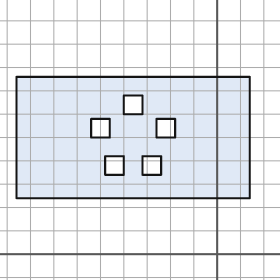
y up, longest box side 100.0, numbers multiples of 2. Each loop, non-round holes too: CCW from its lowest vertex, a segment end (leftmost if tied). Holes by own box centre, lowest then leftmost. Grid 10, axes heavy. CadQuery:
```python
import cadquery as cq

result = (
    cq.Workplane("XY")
    .moveTo(-86.0, 24.0)
    .lineTo(14.0, 24.0)
    .lineTo(14.0, 76.0)
    .lineTo(-86.0, 76.0)
    .close()
    .moveTo(-48.0, 34.0)
    .lineTo(-40.0, 34.0)
    .lineTo(-40.0, 42.0)
    .lineTo(-48.0, 42.0)
    .close()
    .moveTo(-32.0, 34.0)
    .lineTo(-24.0, 34.0)
    .lineTo(-24.0, 42.0)
    .lineTo(-32.0, 42.0)
    .close()
    .moveTo(-54.0, 50.0)
    .lineTo(-46.0, 50.0)
    .lineTo(-46.0, 58.0)
    .lineTo(-54.0, 58.0)
    .close()
    .moveTo(-26.0, 50.0)
    .lineTo(-18.0, 50.0)
    .lineTo(-18.0, 58.0)
    .lineTo(-26.0, 58.0)
    .close()
    .moveTo(-40.0, 60.0)
    .lineTo(-32.0, 60.0)
    .lineTo(-32.0, 68.0)
    .lineTo(-40.0, 68.0)
    .close()
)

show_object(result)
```